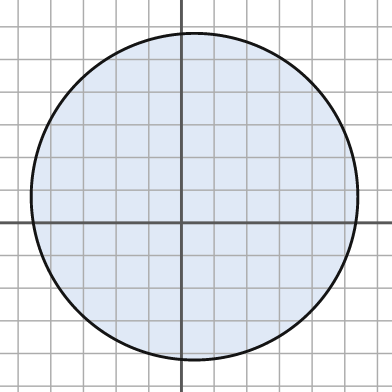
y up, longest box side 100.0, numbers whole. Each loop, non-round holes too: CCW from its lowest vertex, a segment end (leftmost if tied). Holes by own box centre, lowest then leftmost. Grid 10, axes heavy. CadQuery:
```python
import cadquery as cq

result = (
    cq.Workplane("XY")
    .moveTo(4.0, 8.0)
    .circle(50.0)
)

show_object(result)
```